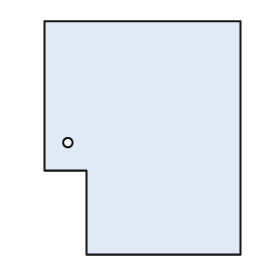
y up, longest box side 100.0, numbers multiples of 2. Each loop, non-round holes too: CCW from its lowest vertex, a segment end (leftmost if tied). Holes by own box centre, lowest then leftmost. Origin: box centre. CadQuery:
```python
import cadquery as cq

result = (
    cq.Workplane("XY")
    .moveTo(-24.0, -50.0)
    .lineTo(42.0, -50.0)
    .lineTo(42.0, 50.0)
    .lineTo(-42.0, 50.0)
    .lineTo(-42.0, -14.0)
    .lineTo(-24.0, -14.0)
    .close()
    .moveTo(-32.0, -2.0)
    .circle(2.0)
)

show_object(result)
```